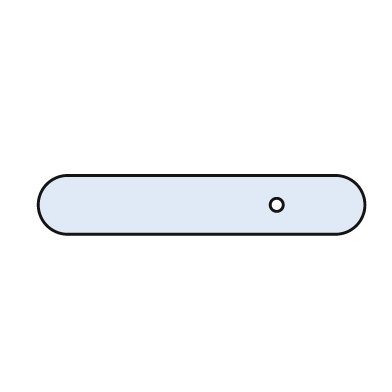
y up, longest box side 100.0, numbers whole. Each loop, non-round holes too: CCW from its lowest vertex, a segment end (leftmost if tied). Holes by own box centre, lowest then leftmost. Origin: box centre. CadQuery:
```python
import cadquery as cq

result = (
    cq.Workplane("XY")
    .moveTo(-41.0, -9.0)
    .lineTo(41.0, -9.0)
    .threePointArc((50.0, 0.0), (41.0, 9.0))
    .lineTo(-41.0, 9.0)
    .threePointArc((-50.0, 0.0), (-41.0, -9.0))
    .close()
    .moveTo(23.0, 0.0)
    .circle(2.0)
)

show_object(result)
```